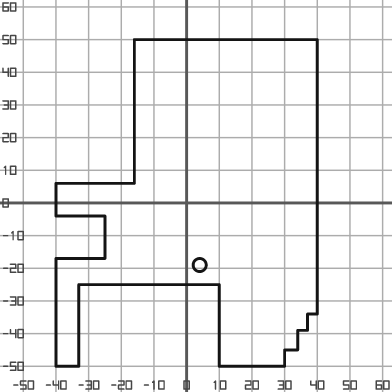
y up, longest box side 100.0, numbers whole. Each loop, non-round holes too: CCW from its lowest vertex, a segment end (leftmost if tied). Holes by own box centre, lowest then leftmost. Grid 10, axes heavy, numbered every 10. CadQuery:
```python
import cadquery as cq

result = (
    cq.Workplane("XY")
    .moveTo(-40.0, -50.0)
    .lineTo(-33.0, -50.0)
    .lineTo(-33.0, -25.0)
    .lineTo(10.0, -25.0)
    .lineTo(10.0, -50.0)
    .lineTo(30.0, -50.0)
    .lineTo(30.0, -45.0)
    .lineTo(34.0, -45.0)
    .lineTo(34.0, -39.0)
    .lineTo(37.0, -39.0)
    .lineTo(37.0, -34.0)
    .lineTo(40.0, -34.0)
    .lineTo(40.0, 50.0)
    .lineTo(-16.0, 50.0)
    .lineTo(-16.0, 6.0)
    .lineTo(-40.0, 6.0)
    .lineTo(-40.0, -4.0)
    .lineTo(-25.0, -4.0)
    .lineTo(-25.0, -17.0)
    .lineTo(-40.0, -17.0)
    .close()
    .moveTo(4.0, -19.0)
    .circle(2.0)
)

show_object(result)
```